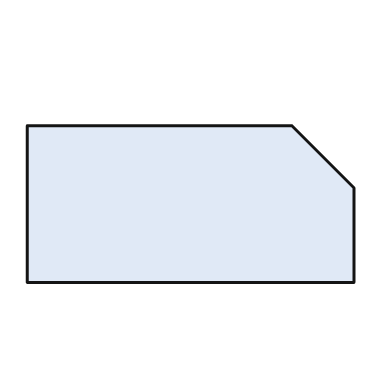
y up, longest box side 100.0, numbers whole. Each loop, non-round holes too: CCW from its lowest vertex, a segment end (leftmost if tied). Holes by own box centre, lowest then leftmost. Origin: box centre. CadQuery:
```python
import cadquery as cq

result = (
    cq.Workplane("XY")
    .moveTo(-50.0, -24.0)
    .lineTo(50.0, -24.0)
    .lineTo(50.0, 5.0)
    .lineTo(31.0, 24.0)
    .lineTo(-50.0, 24.0)
    .close()
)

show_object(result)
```